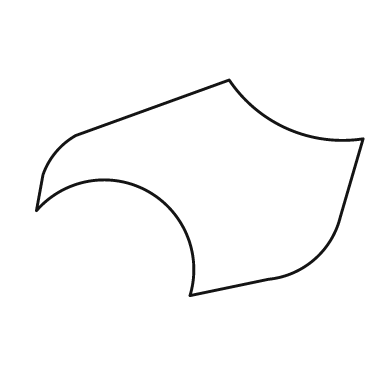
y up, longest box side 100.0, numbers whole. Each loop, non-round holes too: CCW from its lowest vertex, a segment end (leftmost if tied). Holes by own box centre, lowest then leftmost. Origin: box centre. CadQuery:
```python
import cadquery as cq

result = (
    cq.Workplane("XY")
    .moveTo(-3.0, -33.0)
    .lineTo(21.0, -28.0)
    .threePointArc((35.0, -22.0), (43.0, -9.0))
    .lineTo(50.0, 15.0)
    .threePointArc((27.0, 18.0), (9.0, 33.0))
    .lineTo(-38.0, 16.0)
    .threePointArc((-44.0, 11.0), (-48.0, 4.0))
    .lineTo(-50.0, -7.0)
    .threePointArc((-16.0, -1.0), (-3.0, -33.0))
    .close()
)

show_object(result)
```